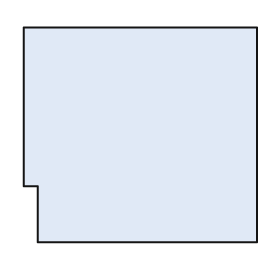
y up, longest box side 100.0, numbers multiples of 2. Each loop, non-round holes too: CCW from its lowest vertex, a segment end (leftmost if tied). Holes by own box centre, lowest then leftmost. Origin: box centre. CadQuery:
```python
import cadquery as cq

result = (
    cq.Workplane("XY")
    .moveTo(-44.0, -46.0)
    .lineTo(50.0, -46.0)
    .lineTo(50.0, 46.0)
    .lineTo(-50.0, 46.0)
    .lineTo(-50.0, -22.0)
    .lineTo(-44.0, -22.0)
    .close()
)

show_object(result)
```